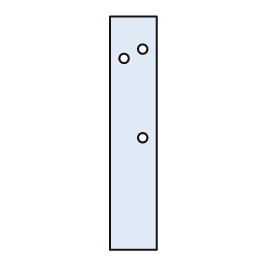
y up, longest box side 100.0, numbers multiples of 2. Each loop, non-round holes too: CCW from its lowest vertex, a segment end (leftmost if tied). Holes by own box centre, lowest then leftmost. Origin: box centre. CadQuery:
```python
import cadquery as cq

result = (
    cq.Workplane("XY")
    .moveTo(-10.0, -50.0)
    .lineTo(10.0, -50.0)
    .lineTo(10.0, 50.0)
    .lineTo(-10.0, 50.0)
    .close()
    .moveTo(4.0, -2.0)
    .circle(2.0)
    .moveTo(-4.0, 32.0)
    .circle(2.0)
    .moveTo(4.0, 36.0)
    .circle(2.0)
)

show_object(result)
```